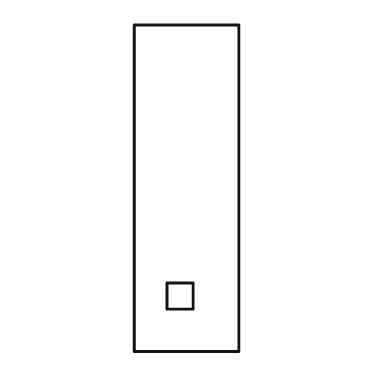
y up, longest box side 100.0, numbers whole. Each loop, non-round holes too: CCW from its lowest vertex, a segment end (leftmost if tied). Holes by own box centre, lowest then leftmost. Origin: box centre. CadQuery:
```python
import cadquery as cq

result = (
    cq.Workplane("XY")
    .moveTo(-16.0, -50.0)
    .lineTo(16.0, -50.0)
    .lineTo(16.0, 50.0)
    .lineTo(-16.0, 50.0)
    .close()
    .moveTo(-6.0, -37.0)
    .lineTo(2.0, -37.0)
    .lineTo(2.0, -29.0)
    .lineTo(-6.0, -29.0)
    .close()
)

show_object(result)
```